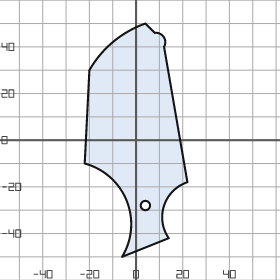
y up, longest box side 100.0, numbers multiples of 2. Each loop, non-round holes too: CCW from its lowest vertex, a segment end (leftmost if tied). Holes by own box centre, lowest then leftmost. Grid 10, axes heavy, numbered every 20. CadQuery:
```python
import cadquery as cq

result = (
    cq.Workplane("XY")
    .moveTo(-6.0, -50.0)
    .lineTo(14.0, -42.0)
    .threePointArc((12.0, -28.0), (22.0, -18.0))
    .lineTo(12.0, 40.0)
    .threePointArc((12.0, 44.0), (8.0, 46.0))
    .lineTo(4.0, 50.0)
    .threePointArc((-10.0, 42.0), (-20.0, 30.0))
    .lineTo(-22.0, -10.0)
    .threePointArc((-4.0, -26.0), (-6.0, -50.0))
    .close()
    .moveTo(4.0, -28.0)
    .circle(2.0)
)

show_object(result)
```